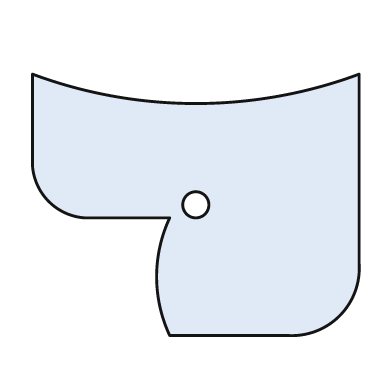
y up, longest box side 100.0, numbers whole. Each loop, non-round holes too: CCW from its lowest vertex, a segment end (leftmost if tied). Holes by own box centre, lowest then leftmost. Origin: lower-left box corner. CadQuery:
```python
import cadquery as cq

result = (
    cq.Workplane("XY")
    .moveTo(42.0, 0.0)
    .lineTo(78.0, 0.0)
    .threePointArc((94.0, 6.0), (100.0, 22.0))
    .lineTo(100.0, 80.0)
    .threePointArc((50.0, 71.0), (0.0, 80.0))
    .lineTo(0.0, 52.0)
    .threePointArc((5.0, 41.0), (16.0, 36.0))
    .lineTo(42.0, 36.0)
    .threePointArc((38.0, 18.0), (42.0, 0.0))
    .close()
    .moveTo(50.0, 40.0)
    .circle(4.0)
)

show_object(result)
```